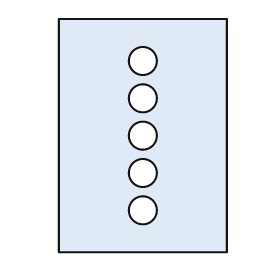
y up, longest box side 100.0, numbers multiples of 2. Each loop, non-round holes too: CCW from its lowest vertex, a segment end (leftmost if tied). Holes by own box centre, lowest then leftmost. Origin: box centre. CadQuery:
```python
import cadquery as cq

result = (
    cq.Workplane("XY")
    .moveTo(-36.0, -50.0)
    .lineTo(36.0, -50.0)
    .lineTo(36.0, 50.0)
    .lineTo(-36.0, 50.0)
    .close()
    .moveTo(0.0, -32.0)
    .circle(6.0)
    .moveTo(0.0, -16.0)
    .circle(6.0)
    .moveTo(0.0, 0.0)
    .circle(6.0)
    .moveTo(0.0, 16.0)
    .circle(6.0)
    .moveTo(0.0, 32.0)
    .circle(6.0)
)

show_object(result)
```